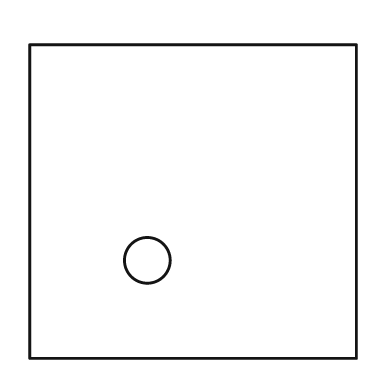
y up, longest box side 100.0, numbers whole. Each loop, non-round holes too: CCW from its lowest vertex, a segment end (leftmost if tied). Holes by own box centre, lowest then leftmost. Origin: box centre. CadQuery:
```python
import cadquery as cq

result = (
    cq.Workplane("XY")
    .moveTo(-50.0, -48.0)
    .lineTo(50.0, -48.0)
    .lineTo(50.0, 48.0)
    .lineTo(-50.0, 48.0)
    .close()
    .moveTo(-14.0, -18.0)
    .circle(7.0)
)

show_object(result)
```